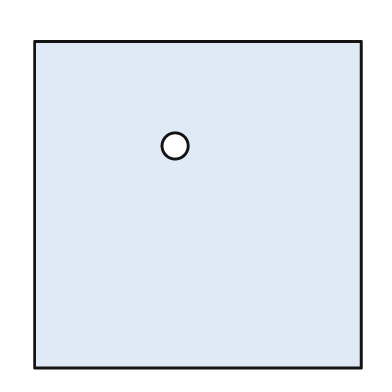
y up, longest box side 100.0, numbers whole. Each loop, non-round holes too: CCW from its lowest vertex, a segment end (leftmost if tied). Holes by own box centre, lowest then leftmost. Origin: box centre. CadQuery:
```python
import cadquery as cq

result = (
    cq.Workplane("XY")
    .moveTo(-50.0, -50.0)
    .lineTo(50.0, -50.0)
    .lineTo(50.0, 50.0)
    .lineTo(-50.0, 50.0)
    .close()
    .moveTo(-7.0, 18.0)
    .circle(4.0)
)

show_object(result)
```